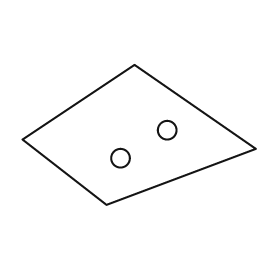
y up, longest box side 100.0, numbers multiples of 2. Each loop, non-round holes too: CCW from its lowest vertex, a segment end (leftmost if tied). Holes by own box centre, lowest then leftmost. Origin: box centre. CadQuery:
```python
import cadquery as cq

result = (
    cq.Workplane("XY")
    .moveTo(-14.0, -30.0)
    .lineTo(50.0, -6.0)
    .lineTo(-2.0, 30.0)
    .lineTo(-50.0, -2.0)
    .close()
    .moveTo(-8.0, -10.0)
    .circle(4.0)
    .moveTo(12.0, 2.0)
    .circle(4.0)
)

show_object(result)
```